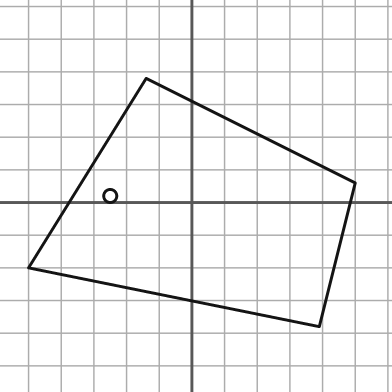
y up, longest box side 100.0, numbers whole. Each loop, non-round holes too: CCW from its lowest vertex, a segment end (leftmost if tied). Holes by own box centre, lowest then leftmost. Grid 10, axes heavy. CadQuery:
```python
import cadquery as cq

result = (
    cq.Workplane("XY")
    .moveTo(39.0, -38.0)
    .lineTo(50.0, 6.0)
    .lineTo(-14.0, 38.0)
    .lineTo(-50.0, -20.0)
    .close()
    .moveTo(-25.0, 2.0)
    .circle(2.0)
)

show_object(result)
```